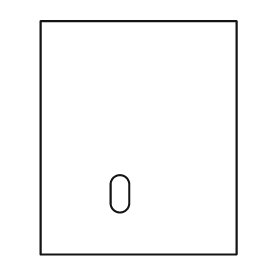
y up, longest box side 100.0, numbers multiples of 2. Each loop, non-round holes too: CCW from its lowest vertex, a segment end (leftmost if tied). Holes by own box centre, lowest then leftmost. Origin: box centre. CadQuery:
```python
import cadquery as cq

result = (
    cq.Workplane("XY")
    .moveTo(-42.0, -50.0)
    .lineTo(42.0, -50.0)
    .lineTo(42.0, 50.0)
    .lineTo(-42.0, 50.0)
    .close()
    .moveTo(-12.0, -28.0)
    .threePointArc((-8.0, -32.0), (-4.0, -28.0))
    .lineTo(-4.0, -20.0)
    .threePointArc((-8.0, -16.0), (-12.0, -20.0))
    .close()
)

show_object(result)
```